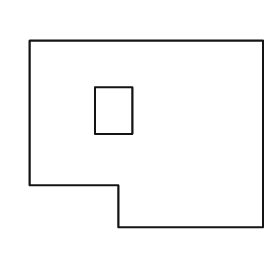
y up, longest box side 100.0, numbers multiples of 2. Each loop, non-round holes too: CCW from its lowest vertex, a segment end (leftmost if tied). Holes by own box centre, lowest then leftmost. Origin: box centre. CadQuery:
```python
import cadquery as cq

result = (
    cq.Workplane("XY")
    .moveTo(-12.0, -40.0)
    .lineTo(50.0, -40.0)
    .lineTo(50.0, 40.0)
    .lineTo(-50.0, 40.0)
    .lineTo(-50.0, -22.0)
    .lineTo(-12.0, -22.0)
    .close()
    .moveTo(-22.0, 0.0)
    .lineTo(-6.0, 0.0)
    .lineTo(-6.0, 20.0)
    .lineTo(-22.0, 20.0)
    .close()
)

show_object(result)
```